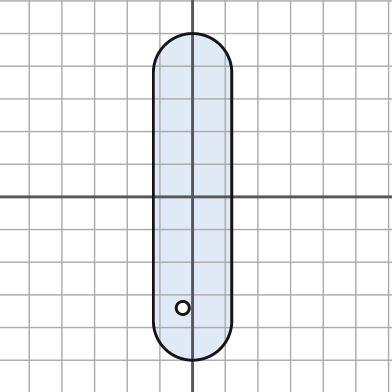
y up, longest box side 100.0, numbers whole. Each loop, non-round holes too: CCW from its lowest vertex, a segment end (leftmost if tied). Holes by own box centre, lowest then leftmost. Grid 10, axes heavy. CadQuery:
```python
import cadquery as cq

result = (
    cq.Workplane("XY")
    .moveTo(-12.0, -38.0)
    .threePointArc((0.0, -50.0), (12.0, -38.0))
    .lineTo(12.0, 38.0)
    .threePointArc((0.0, 50.0), (-12.0, 38.0))
    .close()
    .moveTo(-3.0, -34.0)
    .circle(2.0)
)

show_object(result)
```